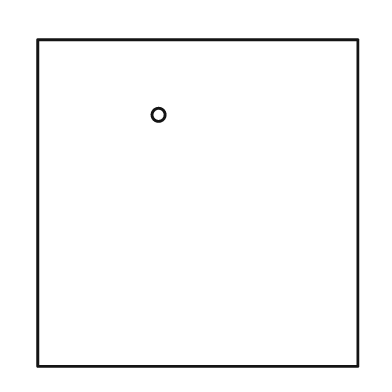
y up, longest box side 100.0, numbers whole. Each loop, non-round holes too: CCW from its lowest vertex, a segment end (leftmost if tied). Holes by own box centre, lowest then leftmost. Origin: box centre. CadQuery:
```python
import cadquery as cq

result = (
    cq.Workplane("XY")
    .moveTo(-49.0, -50.0)
    .lineTo(49.0, -50.0)
    .lineTo(49.0, 50.0)
    .lineTo(-49.0, 50.0)
    .close()
    .moveTo(-12.0, 27.0)
    .circle(2.0)
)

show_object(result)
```